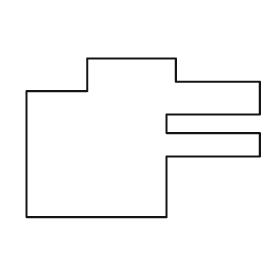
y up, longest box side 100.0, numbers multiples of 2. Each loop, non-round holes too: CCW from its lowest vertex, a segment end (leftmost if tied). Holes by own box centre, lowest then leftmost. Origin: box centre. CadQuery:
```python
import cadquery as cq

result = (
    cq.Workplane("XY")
    .moveTo(-50.0, -34.0)
    .lineTo(10.0, -34.0)
    .lineTo(10.0, -8.0)
    .lineTo(50.0, -8.0)
    .lineTo(50.0, 2.0)
    .lineTo(10.0, 2.0)
    .lineTo(10.0, 10.0)
    .lineTo(50.0, 10.0)
    .lineTo(50.0, 24.0)
    .lineTo(14.0, 24.0)
    .lineTo(14.0, 34.0)
    .lineTo(-24.0, 34.0)
    .lineTo(-24.0, 20.0)
    .lineTo(-50.0, 20.0)
    .close()
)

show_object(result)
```